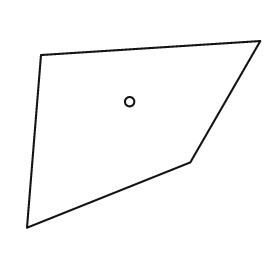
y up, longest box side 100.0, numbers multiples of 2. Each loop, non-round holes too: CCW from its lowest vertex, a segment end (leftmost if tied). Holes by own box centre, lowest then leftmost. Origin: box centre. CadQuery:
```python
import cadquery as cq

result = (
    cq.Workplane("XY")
    .moveTo(-50.0, -40.0)
    .lineTo(20.0, -12.0)
    .lineTo(50.0, 40.0)
    .lineTo(-44.0, 34.0)
    .close()
    .moveTo(-6.0, 14.0)
    .circle(2.0)
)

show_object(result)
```